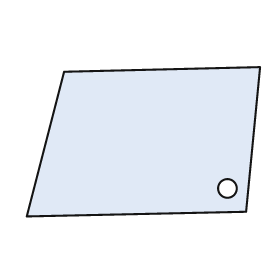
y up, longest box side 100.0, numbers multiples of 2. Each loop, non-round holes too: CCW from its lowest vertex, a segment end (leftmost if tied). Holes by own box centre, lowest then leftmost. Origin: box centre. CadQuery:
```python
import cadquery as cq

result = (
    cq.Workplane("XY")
    .moveTo(-50.0, -32.0)
    .lineTo(44.0, -30.0)
    .lineTo(50.0, 32.0)
    .lineTo(-34.0, 30.0)
    .close()
    .moveTo(36.0, -20.0)
    .circle(4.0)
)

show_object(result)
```